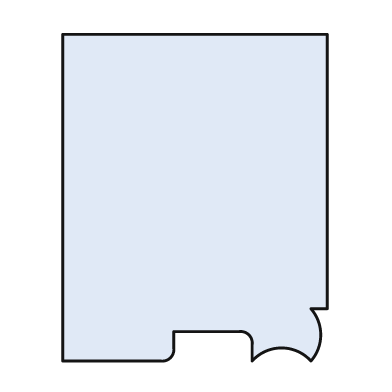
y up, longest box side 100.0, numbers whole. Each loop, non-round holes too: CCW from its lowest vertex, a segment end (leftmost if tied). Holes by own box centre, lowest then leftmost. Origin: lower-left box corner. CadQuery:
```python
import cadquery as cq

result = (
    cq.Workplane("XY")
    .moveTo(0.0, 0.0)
    .lineTo(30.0, 0.0)
    .threePointArc((33.0, 1.0), (34.0, 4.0))
    .lineTo(34.0, 9.0)
    .lineTo(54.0, 9.0)
    .threePointArc((57.0, 8.0), (58.0, 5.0))
    .lineTo(58.0, 0.0)
    .threePointArc((67.0, 4.0), (76.0, 0.0))
    .threePointArc((79.0, 8.0), (76.0, 16.0))
    .lineTo(81.0, 16.0)
    .lineTo(81.0, 100.0)
    .lineTo(0.0, 100.0)
    .close()
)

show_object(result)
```